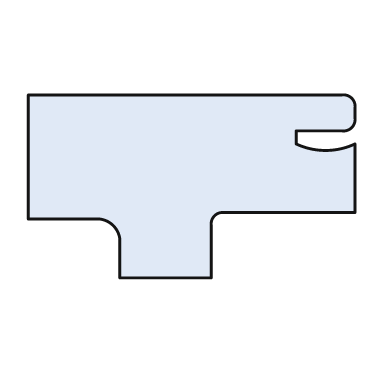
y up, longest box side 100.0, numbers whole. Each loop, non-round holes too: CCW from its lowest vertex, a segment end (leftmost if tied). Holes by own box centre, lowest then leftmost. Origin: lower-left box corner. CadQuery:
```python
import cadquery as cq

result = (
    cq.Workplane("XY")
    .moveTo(28.0, 0.0)
    .lineTo(56.0, 0.0)
    .lineTo(56.0, 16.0)
    .threePointArc((57.0, 19.0), (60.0, 20.0))
    .lineTo(100.0, 20.0)
    .lineTo(100.0, 41.0)
    .threePointArc((91.0, 39.0), (82.0, 41.0))
    .lineTo(82.0, 45.0)
    .lineTo(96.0, 45.0)
    .threePointArc((99.0, 46.0), (100.0, 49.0))
    .lineTo(100.0, 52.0)
    .threePointArc((99.0, 55.0), (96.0, 56.0))
    .lineTo(0.0, 56.0)
    .lineTo(0.0, 18.0)
    .lineTo(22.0, 18.0)
    .threePointArc((26.0, 16.0), (28.0, 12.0))
    .close()
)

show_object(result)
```